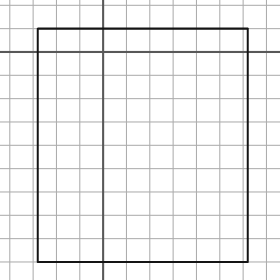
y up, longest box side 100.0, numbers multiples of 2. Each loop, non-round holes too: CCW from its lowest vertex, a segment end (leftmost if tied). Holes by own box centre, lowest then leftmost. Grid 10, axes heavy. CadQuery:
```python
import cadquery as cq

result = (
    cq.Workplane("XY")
    .moveTo(-28.0, -90.0)
    .lineTo(62.0, -90.0)
    .lineTo(62.0, 10.0)
    .lineTo(-28.0, 10.0)
    .close()
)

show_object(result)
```